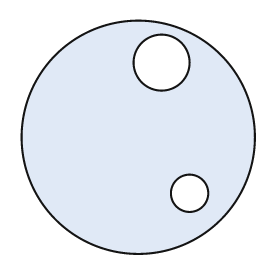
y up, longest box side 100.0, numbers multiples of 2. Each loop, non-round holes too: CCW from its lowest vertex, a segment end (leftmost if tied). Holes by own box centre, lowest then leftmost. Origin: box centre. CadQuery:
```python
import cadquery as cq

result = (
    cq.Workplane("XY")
    .moveTo(0.0, 0.0)
    .circle(50.0)
    .moveTo(22.0, -24.0)
    .circle(8.0)
    .moveTo(10.0, 32.0)
    .circle(12.0)
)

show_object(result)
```